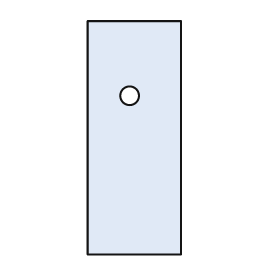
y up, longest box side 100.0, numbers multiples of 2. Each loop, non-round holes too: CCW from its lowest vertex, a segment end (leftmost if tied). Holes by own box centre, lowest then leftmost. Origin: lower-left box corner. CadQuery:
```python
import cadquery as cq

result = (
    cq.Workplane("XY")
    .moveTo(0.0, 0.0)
    .lineTo(40.0, 0.0)
    .lineTo(40.0, 100.0)
    .lineTo(0.0, 100.0)
    .close()
    .moveTo(18.0, 68.0)
    .circle(4.0)
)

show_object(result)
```